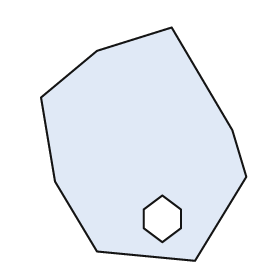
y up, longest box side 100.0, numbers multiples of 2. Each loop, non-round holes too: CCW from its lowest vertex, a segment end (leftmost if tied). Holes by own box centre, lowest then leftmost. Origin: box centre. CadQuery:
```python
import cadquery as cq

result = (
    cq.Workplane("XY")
    .moveTo(22.0, -50.0)
    .lineTo(44.0, -14.0)
    .lineTo(38.0, 6.0)
    .lineTo(12.0, 50.0)
    .lineTo(-20.0, 40.0)
    .lineTo(-44.0, 20.0)
    .lineTo(-38.0, -16.0)
    .lineTo(-20.0, -46.0)
    .close()
    .moveTo(8.0, -42.0)
    .lineTo(16.0, -36.0)
    .lineTo(16.0, -28.0)
    .lineTo(8.0, -22.0)
    .lineTo(0.0, -28.0)
    .lineTo(0.0, -36.0)
    .close()
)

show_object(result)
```